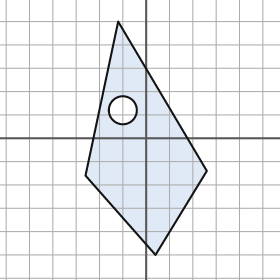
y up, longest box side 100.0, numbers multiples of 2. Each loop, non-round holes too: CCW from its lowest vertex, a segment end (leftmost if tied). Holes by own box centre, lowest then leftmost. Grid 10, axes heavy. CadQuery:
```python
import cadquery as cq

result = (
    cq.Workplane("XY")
    .moveTo(4.0, -50.0)
    .lineTo(26.0, -14.0)
    .lineTo(-12.0, 50.0)
    .lineTo(-26.0, -16.0)
    .close()
    .moveTo(-10.0, 12.0)
    .circle(6.0)
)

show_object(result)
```